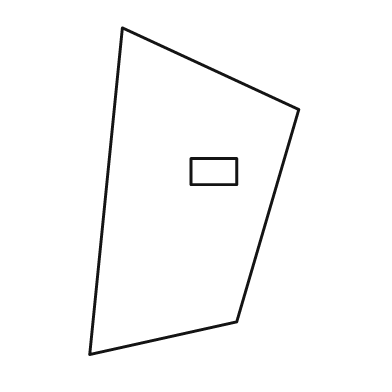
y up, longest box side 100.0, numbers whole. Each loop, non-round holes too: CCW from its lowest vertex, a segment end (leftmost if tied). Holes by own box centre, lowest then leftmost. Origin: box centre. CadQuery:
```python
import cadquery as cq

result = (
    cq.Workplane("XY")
    .moveTo(-32.0, -50.0)
    .lineTo(13.0, -40.0)
    .lineTo(32.0, 25.0)
    .lineTo(-22.0, 50.0)
    .close()
    .moveTo(-1.0, 2.0)
    .lineTo(13.0, 2.0)
    .lineTo(13.0, 10.0)
    .lineTo(-1.0, 10.0)
    .close()
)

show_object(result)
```